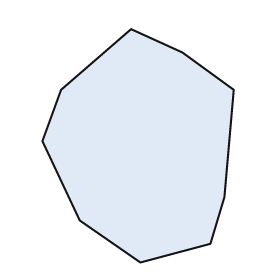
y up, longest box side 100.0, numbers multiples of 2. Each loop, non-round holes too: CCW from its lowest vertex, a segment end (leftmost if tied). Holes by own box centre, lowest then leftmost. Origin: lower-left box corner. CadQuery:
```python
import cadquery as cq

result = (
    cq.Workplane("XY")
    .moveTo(42.0, 0.0)
    .lineTo(72.0, 8.0)
    .lineTo(78.0, 28.0)
    .lineTo(82.0, 74.0)
    .lineTo(60.0, 90.0)
    .lineTo(38.0, 100.0)
    .lineTo(8.0, 74.0)
    .lineTo(0.0, 52.0)
    .lineTo(16.0, 18.0)
    .close()
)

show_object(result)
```